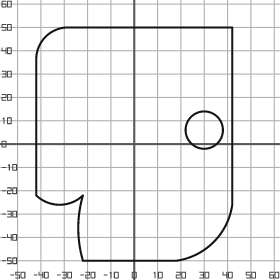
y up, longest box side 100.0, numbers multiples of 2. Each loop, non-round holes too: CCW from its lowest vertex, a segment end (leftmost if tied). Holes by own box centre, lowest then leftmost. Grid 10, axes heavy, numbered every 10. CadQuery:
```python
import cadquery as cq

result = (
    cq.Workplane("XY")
    .moveTo(-22.0, -50.0)
    .lineTo(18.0, -50.0)
    .threePointArc((34.0, -42.0), (42.0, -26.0))
    .lineTo(42.0, 50.0)
    .lineTo(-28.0, 50.0)
    .threePointArc((-38.0, 46.0), (-42.0, 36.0))
    .lineTo(-42.0, -22.0)
    .threePointArc((-32.0, -26.0), (-22.0, -22.0))
    .threePointArc((-24.0, -36.0), (-22.0, -50.0))
    .close()
    .moveTo(30.0, 6.0)
    .circle(8.0)
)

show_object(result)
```